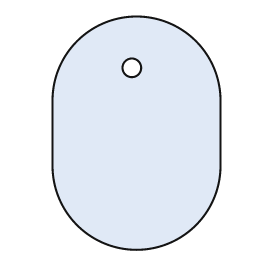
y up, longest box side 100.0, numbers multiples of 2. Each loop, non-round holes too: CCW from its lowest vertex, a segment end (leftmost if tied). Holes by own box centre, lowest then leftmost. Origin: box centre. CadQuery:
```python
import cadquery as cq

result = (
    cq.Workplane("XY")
    .moveTo(-36.0, -14.0)
    .threePointArc((0.0, -50.0), (36.0, -14.0))
    .lineTo(36.0, 14.0)
    .threePointArc((0.0, 50.0), (-36.0, 14.0))
    .close()
    .moveTo(-2.0, 28.0)
    .circle(4.0)
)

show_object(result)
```